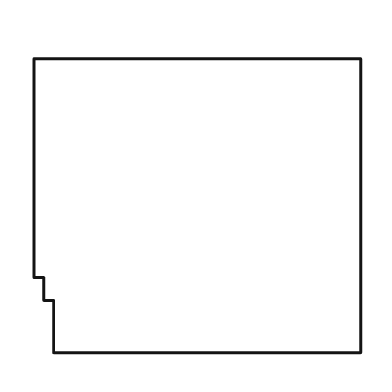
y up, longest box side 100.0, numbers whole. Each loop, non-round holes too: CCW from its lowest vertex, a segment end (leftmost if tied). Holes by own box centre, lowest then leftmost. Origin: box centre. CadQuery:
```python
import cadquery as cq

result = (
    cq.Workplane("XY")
    .moveTo(-44.0, -45.0)
    .lineTo(50.0, -45.0)
    .lineTo(50.0, 45.0)
    .lineTo(-50.0, 45.0)
    .lineTo(-50.0, -22.0)
    .lineTo(-47.0, -22.0)
    .lineTo(-47.0, -29.0)
    .lineTo(-44.0, -29.0)
    .close()
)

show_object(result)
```